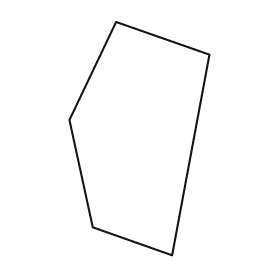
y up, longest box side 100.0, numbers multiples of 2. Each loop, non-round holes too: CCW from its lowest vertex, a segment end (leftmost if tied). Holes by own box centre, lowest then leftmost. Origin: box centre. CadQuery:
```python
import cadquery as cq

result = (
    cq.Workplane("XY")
    .moveTo(14.0, -50.0)
    .lineTo(30.0, 36.0)
    .lineTo(-10.0, 50.0)
    .lineTo(-30.0, 8.0)
    .lineTo(-20.0, -38.0)
    .close()
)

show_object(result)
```